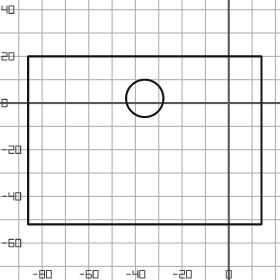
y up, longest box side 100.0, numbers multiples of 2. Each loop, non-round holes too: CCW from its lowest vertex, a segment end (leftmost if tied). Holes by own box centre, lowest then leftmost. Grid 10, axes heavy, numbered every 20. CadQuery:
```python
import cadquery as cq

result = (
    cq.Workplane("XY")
    .moveTo(-86.0, -52.0)
    .lineTo(14.0, -52.0)
    .lineTo(14.0, 20.0)
    .lineTo(-86.0, 20.0)
    .close()
    .moveTo(-36.0, 2.0)
    .circle(8.0)
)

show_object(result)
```